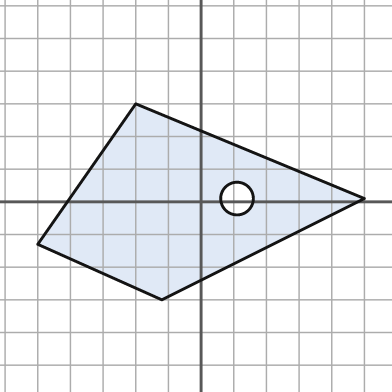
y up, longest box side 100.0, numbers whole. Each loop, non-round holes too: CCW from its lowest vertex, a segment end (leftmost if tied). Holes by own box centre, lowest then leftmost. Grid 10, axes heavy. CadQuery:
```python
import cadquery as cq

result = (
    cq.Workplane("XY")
    .moveTo(-12.0, -30.0)
    .lineTo(50.0, 1.0)
    .lineTo(-20.0, 30.0)
    .lineTo(-50.0, -13.0)
    .close()
    .moveTo(11.0, 1.0)
    .circle(5.0)
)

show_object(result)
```